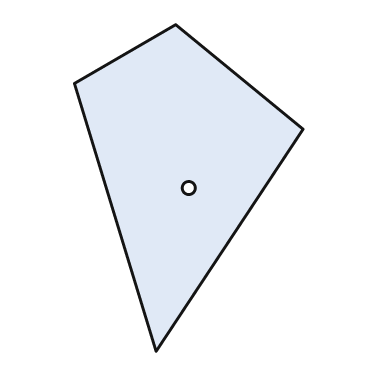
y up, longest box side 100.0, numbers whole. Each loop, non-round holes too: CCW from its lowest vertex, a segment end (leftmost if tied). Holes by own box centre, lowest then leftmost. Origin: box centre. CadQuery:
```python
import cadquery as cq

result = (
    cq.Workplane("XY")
    .moveTo(-10.0, -50.0)
    .lineTo(35.0, 18.0)
    .lineTo(-4.0, 50.0)
    .lineTo(-35.0, 32.0)
    .close()
    .moveTo(0.0, 0.0)
    .circle(2.0)
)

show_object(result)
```